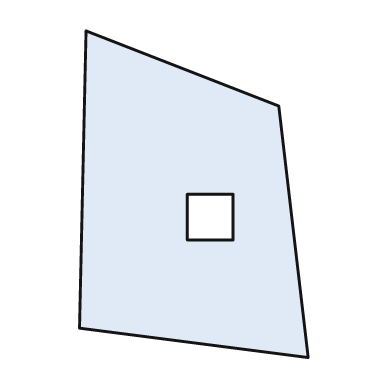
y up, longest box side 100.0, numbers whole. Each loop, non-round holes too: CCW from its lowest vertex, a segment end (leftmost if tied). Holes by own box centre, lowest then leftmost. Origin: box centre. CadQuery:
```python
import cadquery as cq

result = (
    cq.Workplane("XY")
    .moveTo(35.0, -50.0)
    .lineTo(26.0, 27.0)
    .lineTo(-33.0, 50.0)
    .lineTo(-35.0, -41.0)
    .close()
    .moveTo(-2.0, -14.0)
    .lineTo(12.0, -14.0)
    .lineTo(12.0, 0.0)
    .lineTo(-2.0, 0.0)
    .close()
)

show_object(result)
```